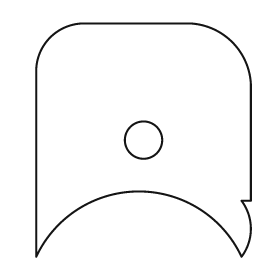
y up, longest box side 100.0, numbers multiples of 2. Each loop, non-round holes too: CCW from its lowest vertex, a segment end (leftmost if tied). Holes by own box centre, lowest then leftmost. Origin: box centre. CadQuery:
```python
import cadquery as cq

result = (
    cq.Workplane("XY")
    .moveTo(-46.0, -50.0)
    .threePointArc((-2.0, -22.0), (42.0, -50.0))
    .threePointArc((46.0, -38.0), (42.0, -26.0))
    .lineTo(46.0, -26.0)
    .lineTo(46.0, 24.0)
    .threePointArc((38.0, 42.0), (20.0, 50.0))
    .lineTo(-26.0, 50.0)
    .threePointArc((-40.0, 44.0), (-46.0, 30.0))
    .close()
    .moveTo(0.0, 0.0)
    .circle(8.0)
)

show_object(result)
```